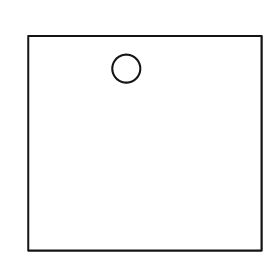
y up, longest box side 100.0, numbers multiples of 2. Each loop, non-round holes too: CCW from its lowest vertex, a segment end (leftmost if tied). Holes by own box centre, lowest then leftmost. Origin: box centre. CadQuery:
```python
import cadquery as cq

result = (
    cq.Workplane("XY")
    .moveTo(-50.0, -46.0)
    .lineTo(50.0, -46.0)
    .lineTo(50.0, 46.0)
    .lineTo(-50.0, 46.0)
    .close()
    .moveTo(-8.0, 32.0)
    .circle(6.0)
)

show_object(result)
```